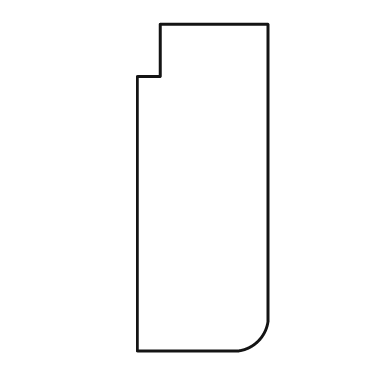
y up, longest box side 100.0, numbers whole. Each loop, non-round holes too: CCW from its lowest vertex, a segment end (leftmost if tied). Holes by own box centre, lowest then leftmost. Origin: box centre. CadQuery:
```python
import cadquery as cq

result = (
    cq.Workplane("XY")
    .moveTo(-20.0, -50.0)
    .lineTo(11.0, -50.0)
    .threePointArc((17.0, -47.0), (20.0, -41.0))
    .lineTo(20.0, 50.0)
    .lineTo(-13.0, 50.0)
    .lineTo(-13.0, 34.0)
    .lineTo(-20.0, 34.0)
    .close()
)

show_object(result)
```